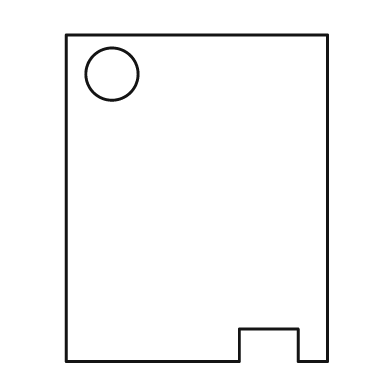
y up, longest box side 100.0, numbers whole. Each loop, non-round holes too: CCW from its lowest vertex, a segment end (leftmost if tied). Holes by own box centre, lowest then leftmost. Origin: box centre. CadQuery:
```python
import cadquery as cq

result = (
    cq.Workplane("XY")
    .moveTo(-40.0, -50.0)
    .lineTo(13.0, -50.0)
    .lineTo(13.0, -40.0)
    .lineTo(31.0, -40.0)
    .lineTo(31.0, -50.0)
    .lineTo(40.0, -50.0)
    .lineTo(40.0, 50.0)
    .lineTo(-40.0, 50.0)
    .close()
    .moveTo(-26.0, 38.0)
    .circle(8.0)
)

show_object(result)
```